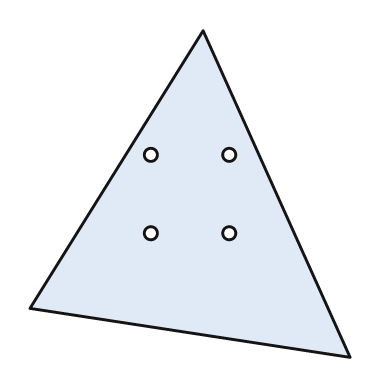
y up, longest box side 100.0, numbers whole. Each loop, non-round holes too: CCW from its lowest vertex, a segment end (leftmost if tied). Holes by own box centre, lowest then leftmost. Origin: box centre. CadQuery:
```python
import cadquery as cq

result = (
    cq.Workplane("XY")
    .moveTo(49.0, -50.0)
    .lineTo(4.0, 50.0)
    .lineTo(-49.0, -35.0)
    .close()
    .moveTo(-12.0, -12.0)
    .circle(2.0)
    .moveTo(12.0, -12.0)
    .circle(2.0)
    .moveTo(-12.0, 12.0)
    .circle(2.0)
    .moveTo(12.0, 12.0)
    .circle(2.0)
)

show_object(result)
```